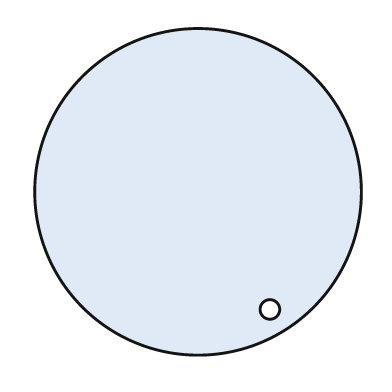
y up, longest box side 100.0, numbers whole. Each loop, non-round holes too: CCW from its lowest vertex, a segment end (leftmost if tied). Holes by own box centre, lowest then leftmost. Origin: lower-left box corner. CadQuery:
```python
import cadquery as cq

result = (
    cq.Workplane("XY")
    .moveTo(50.0, 50.0)
    .circle(50.0)
    .moveTo(72.0, 14.0)
    .circle(3.0)
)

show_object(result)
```